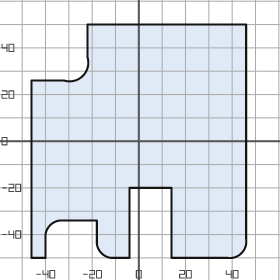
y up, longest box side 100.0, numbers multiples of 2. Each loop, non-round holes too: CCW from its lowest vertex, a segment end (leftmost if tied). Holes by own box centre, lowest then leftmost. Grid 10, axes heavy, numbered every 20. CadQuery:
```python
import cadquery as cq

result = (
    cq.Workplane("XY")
    .moveTo(-46.0, -50.0)
    .lineTo(-40.0, -50.0)
    .lineTo(-40.0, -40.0)
    .threePointArc((-38.0, -36.0), (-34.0, -34.0))
    .lineTo(-18.0, -34.0)
    .lineTo(-18.0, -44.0)
    .threePointArc((-16.0, -48.0), (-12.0, -50.0))
    .lineTo(-4.0, -50.0)
    .lineTo(-4.0, -20.0)
    .lineTo(14.0, -20.0)
    .lineTo(14.0, -50.0)
    .lineTo(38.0, -50.0)
    .threePointArc((44.0, -48.0), (46.0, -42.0))
    .lineTo(46.0, 50.0)
    .lineTo(-22.0, 50.0)
    .lineTo(-22.0, 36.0)
    .threePointArc((-24.0, 28.0), (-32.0, 26.0))
    .lineTo(-46.0, 26.0)
    .close()
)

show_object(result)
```